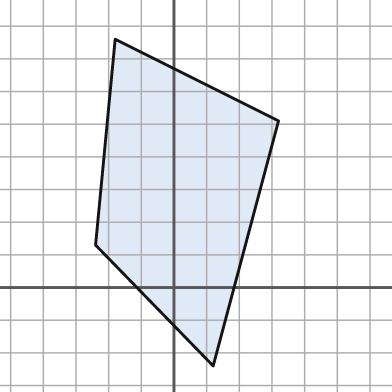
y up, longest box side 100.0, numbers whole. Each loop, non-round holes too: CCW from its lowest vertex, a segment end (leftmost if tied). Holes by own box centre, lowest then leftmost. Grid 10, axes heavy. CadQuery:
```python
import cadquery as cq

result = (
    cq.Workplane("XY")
    .moveTo(12.0, -24.0)
    .lineTo(32.0, 51.0)
    .lineTo(-18.0, 76.0)
    .lineTo(-24.0, 13.0)
    .close()
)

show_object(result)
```